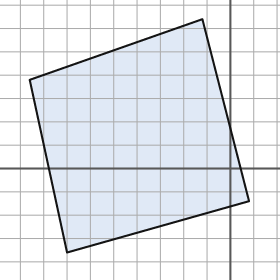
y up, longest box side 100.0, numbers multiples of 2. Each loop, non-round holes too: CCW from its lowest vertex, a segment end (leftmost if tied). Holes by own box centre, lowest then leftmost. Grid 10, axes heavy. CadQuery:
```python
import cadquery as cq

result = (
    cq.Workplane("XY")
    .moveTo(-70.0, -36.0)
    .lineTo(8.0, -14.0)
    .lineTo(-12.0, 64.0)
    .lineTo(-86.0, 38.0)
    .close()
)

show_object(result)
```